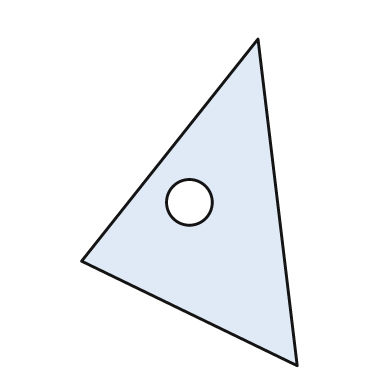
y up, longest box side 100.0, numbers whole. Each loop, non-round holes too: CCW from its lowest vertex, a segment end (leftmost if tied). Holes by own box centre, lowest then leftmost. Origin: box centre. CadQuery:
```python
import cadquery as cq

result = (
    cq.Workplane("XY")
    .moveTo(33.0, -50.0)
    .lineTo(21.0, 50.0)
    .lineTo(-33.0, -18.0)
    .close()
    .moveTo(0.0, 0.0)
    .circle(7.0)
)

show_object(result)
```